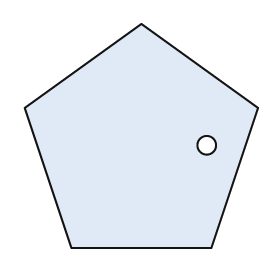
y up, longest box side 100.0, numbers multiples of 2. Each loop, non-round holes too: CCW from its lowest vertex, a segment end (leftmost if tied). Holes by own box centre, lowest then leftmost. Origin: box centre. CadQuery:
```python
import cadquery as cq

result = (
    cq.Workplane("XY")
    .moveTo(-30.0, -48.0)
    .lineTo(30.0, -48.0)
    .lineTo(50.0, 12.0)
    .lineTo(0.0, 48.0)
    .lineTo(-50.0, 12.0)
    .close()
    .moveTo(28.0, -4.0)
    .circle(4.0)
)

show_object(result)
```